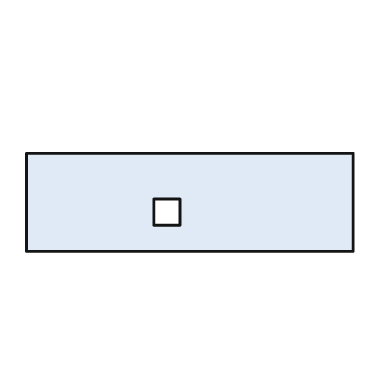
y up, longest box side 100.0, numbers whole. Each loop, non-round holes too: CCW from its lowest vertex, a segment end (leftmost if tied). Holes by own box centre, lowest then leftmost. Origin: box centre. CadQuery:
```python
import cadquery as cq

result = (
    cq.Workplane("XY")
    .moveTo(-50.0, -15.0)
    .lineTo(50.0, -15.0)
    .lineTo(50.0, 15.0)
    .lineTo(-50.0, 15.0)
    .close()
    .moveTo(-11.0, -7.0)
    .lineTo(-3.0, -7.0)
    .lineTo(-3.0, 1.0)
    .lineTo(-11.0, 1.0)
    .close()
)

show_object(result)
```